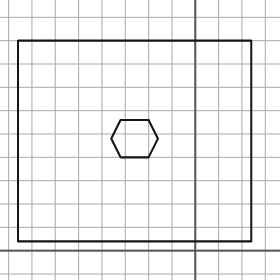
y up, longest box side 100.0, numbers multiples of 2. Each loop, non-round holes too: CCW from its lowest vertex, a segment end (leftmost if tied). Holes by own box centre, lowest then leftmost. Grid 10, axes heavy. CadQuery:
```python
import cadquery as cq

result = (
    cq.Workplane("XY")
    .moveTo(-76.0, 4.0)
    .lineTo(24.0, 4.0)
    .lineTo(24.0, 90.0)
    .lineTo(-76.0, 90.0)
    .close()
    .moveTo(-32.0, 40.0)
    .lineTo(-20.0, 40.0)
    .lineTo(-16.0, 48.0)
    .lineTo(-20.0, 56.0)
    .lineTo(-32.0, 56.0)
    .lineTo(-36.0, 48.0)
    .close()
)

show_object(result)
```